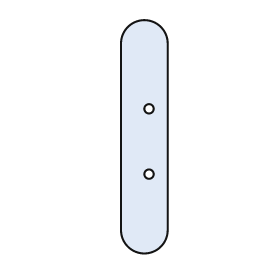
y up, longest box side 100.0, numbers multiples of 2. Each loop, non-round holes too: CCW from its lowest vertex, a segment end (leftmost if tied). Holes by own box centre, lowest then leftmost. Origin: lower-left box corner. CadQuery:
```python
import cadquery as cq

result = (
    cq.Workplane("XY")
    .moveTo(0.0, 10.0)
    .threePointArc((10.0, 0.0), (20.0, 10.0))
    .lineTo(20.0, 90.0)
    .threePointArc((10.0, 100.0), (0.0, 90.0))
    .close()
    .moveTo(12.0, 34.0)
    .circle(2.0)
    .moveTo(12.0, 62.0)
    .circle(2.0)
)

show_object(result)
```